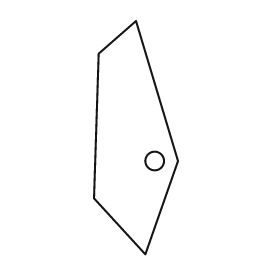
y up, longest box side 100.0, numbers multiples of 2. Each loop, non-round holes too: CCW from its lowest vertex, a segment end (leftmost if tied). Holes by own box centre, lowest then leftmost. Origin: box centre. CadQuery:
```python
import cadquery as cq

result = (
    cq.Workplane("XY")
    .moveTo(4.0, -50.0)
    .lineTo(18.0, -10.0)
    .lineTo(0.0, 50.0)
    .lineTo(-16.0, 36.0)
    .lineTo(-18.0, -26.0)
    .close()
    .moveTo(8.0, -10.0)
    .circle(4.0)
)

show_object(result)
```